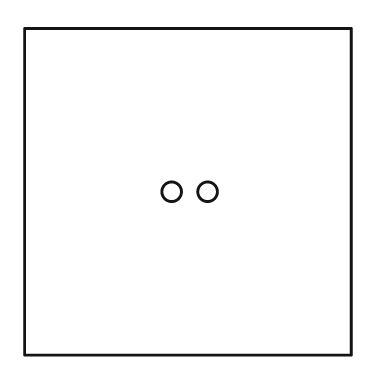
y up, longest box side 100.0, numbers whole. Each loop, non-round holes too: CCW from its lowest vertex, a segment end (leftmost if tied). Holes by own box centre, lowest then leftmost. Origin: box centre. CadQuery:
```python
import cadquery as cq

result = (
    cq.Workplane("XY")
    .moveTo(-50.0, -50.0)
    .lineTo(50.0, -50.0)
    .lineTo(50.0, 50.0)
    .lineTo(-50.0, 50.0)
    .close()
    .moveTo(-5.0, 0.0)
    .circle(3.0)
    .moveTo(6.0, 0.0)
    .circle(3.0)
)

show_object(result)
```